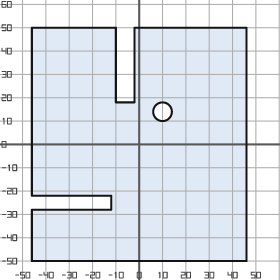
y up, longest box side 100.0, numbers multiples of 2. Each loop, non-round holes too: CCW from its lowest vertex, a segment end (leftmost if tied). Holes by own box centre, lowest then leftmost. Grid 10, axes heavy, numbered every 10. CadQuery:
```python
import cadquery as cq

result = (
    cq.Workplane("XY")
    .moveTo(-46.0, -50.0)
    .lineTo(46.0, -50.0)
    .lineTo(46.0, 50.0)
    .lineTo(-2.0, 50.0)
    .lineTo(-2.0, 18.0)
    .lineTo(-10.0, 18.0)
    .lineTo(-10.0, 50.0)
    .lineTo(-46.0, 50.0)
    .lineTo(-46.0, -22.0)
    .lineTo(-12.0, -22.0)
    .lineTo(-12.0, -28.0)
    .lineTo(-46.0, -28.0)
    .close()
    .moveTo(10.0, 14.0)
    .circle(4.0)
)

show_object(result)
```